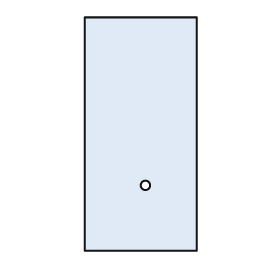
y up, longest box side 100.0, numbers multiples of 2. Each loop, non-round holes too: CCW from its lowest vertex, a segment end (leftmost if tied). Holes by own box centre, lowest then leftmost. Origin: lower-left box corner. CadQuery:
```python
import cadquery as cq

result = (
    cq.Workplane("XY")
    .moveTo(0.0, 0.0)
    .lineTo(48.0, 0.0)
    .lineTo(48.0, 100.0)
    .lineTo(0.0, 100.0)
    .close()
    .moveTo(26.0, 28.0)
    .circle(2.0)
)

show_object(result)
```